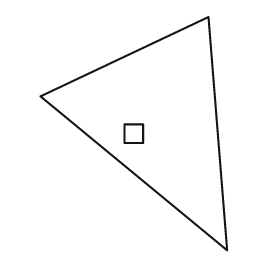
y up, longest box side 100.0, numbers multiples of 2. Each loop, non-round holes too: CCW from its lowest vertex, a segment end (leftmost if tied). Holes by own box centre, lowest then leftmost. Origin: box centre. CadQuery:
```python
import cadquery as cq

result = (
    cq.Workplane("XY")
    .moveTo(40.0, -50.0)
    .lineTo(32.0, 50.0)
    .lineTo(-40.0, 16.0)
    .close()
    .moveTo(-4.0, -4.0)
    .lineTo(4.0, -4.0)
    .lineTo(4.0, 4.0)
    .lineTo(-4.0, 4.0)
    .close()
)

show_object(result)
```